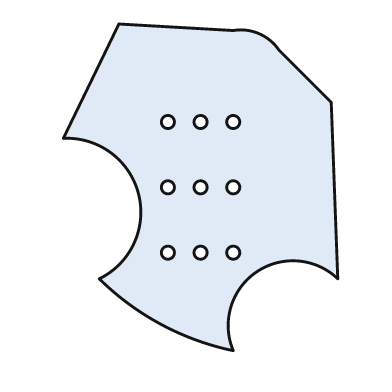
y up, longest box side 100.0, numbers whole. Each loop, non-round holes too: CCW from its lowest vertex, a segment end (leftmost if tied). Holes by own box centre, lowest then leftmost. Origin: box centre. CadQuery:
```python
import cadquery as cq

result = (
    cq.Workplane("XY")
    .moveTo(10.0, -50.0)
    .threePointArc((17.0, -26.0), (42.0, -28.0))
    .lineTo(40.0, 26.0)
    .lineTo(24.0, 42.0)
    .threePointArc((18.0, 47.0), (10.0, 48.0))
    .lineTo(-25.0, 50.0)
    .lineTo(-42.0, 15.0)
    .threePointArc((-19.0, -2.0), (-31.0, -28.0))
    .threePointArc((-12.0, -42.0), (10.0, -50.0))
    .close()
    .moveTo(-10.0, -20.0)
    .circle(2.0)
    .moveTo(0.0, -20.0)
    .circle(2.0)
    .moveTo(10.0, -20.0)
    .circle(2.0)
    .moveTo(-10.0, 0.0)
    .circle(2.0)
    .moveTo(0.0, 0.0)
    .circle(2.0)
    .moveTo(10.0, 0.0)
    .circle(2.0)
    .moveTo(-10.0, 20.0)
    .circle(2.0)
    .moveTo(0.0, 20.0)
    .circle(2.0)
    .moveTo(10.0, 20.0)
    .circle(2.0)
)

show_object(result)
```